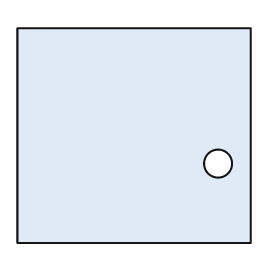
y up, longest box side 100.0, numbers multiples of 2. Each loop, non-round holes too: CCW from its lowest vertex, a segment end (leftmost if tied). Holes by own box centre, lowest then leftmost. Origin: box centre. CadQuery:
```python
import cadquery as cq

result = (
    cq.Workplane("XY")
    .moveTo(-50.0, -46.0)
    .lineTo(50.0, -46.0)
    .lineTo(50.0, 46.0)
    .lineTo(-50.0, 46.0)
    .close()
    .moveTo(36.0, -12.0)
    .circle(6.0)
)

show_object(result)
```